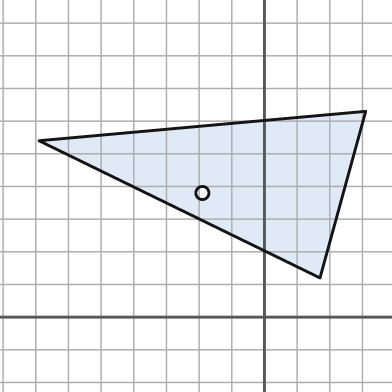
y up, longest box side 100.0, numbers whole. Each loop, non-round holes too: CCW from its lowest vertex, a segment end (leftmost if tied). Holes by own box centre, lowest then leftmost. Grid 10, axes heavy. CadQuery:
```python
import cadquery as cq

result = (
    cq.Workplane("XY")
    .moveTo(17.0, 12.0)
    .lineTo(31.0, 63.0)
    .lineTo(-69.0, 54.0)
    .close()
    .moveTo(-19.0, 38.0)
    .circle(2.0)
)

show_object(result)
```